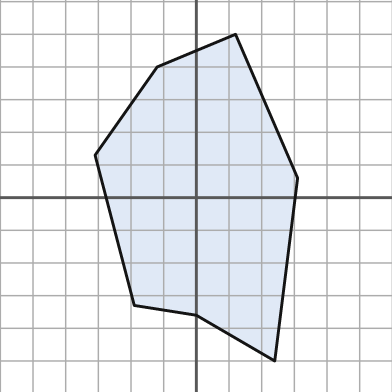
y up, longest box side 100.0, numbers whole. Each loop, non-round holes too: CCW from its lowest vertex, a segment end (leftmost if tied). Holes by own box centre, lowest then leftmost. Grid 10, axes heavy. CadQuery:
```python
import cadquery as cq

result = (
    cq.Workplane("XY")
    .moveTo(24.0, -50.0)
    .lineTo(31.0, 6.0)
    .lineTo(12.0, 50.0)
    .lineTo(-12.0, 40.0)
    .lineTo(-31.0, 13.0)
    .lineTo(-19.0, -33.0)
    .lineTo(0.0, -36.0)
    .close()
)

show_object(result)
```